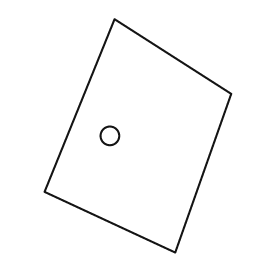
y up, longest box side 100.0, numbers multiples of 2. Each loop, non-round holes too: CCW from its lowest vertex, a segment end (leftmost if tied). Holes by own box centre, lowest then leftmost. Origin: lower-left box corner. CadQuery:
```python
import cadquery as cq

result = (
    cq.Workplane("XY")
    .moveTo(56.0, 0.0)
    .lineTo(80.0, 68.0)
    .lineTo(30.0, 100.0)
    .lineTo(0.0, 26.0)
    .close()
    .moveTo(28.0, 50.0)
    .circle(4.0)
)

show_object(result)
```